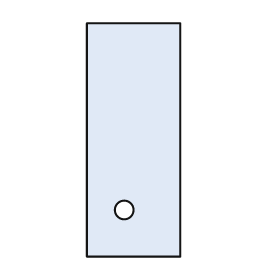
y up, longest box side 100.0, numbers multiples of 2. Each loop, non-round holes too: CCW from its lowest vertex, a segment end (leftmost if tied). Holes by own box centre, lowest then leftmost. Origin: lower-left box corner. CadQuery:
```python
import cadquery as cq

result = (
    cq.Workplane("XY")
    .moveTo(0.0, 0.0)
    .lineTo(40.0, 0.0)
    .lineTo(40.0, 100.0)
    .lineTo(0.0, 100.0)
    .close()
    .moveTo(16.0, 20.0)
    .circle(4.0)
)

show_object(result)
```